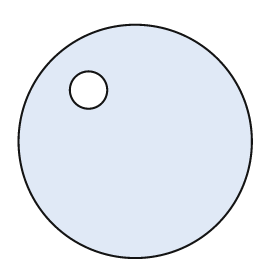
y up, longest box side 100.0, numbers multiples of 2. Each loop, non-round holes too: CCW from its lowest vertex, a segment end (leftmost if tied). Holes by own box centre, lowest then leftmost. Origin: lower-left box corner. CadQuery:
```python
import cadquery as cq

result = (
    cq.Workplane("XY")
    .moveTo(50.0, 50.0)
    .circle(50.0)
    .moveTo(30.0, 72.0)
    .circle(8.0)
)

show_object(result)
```